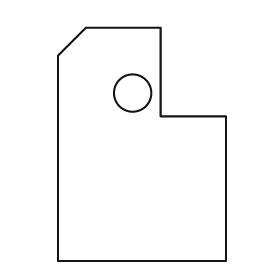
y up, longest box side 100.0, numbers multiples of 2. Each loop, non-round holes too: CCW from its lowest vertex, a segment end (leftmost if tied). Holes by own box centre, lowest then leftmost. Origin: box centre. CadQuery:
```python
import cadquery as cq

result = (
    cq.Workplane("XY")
    .moveTo(-36.0, -50.0)
    .lineTo(36.0, -50.0)
    .lineTo(36.0, 12.0)
    .lineTo(8.0, 12.0)
    .lineTo(8.0, 50.0)
    .lineTo(-24.0, 50.0)
    .lineTo(-36.0, 38.0)
    .close()
    .moveTo(-4.0, 22.0)
    .circle(8.0)
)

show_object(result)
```